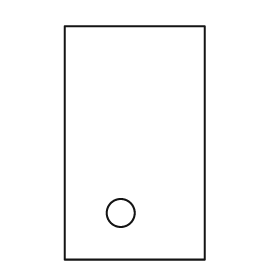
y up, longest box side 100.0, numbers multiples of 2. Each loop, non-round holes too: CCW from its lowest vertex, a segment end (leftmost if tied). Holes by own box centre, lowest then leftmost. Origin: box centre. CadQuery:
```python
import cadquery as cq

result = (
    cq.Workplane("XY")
    .moveTo(-30.0, -50.0)
    .lineTo(30.0, -50.0)
    .lineTo(30.0, 50.0)
    .lineTo(-30.0, 50.0)
    .close()
    .moveTo(-6.0, -30.0)
    .circle(6.0)
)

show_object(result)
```